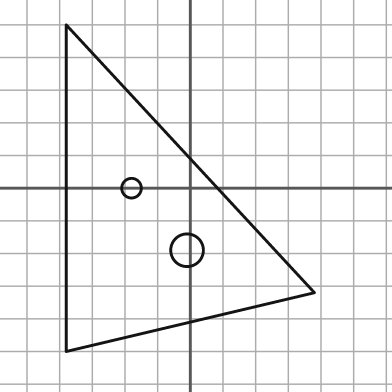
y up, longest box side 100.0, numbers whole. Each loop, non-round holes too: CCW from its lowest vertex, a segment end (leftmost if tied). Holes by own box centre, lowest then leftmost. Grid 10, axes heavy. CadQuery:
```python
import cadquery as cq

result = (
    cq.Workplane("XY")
    .moveTo(-38.0, -50.0)
    .lineTo(38.0, -32.0)
    .lineTo(-38.0, 50.0)
    .close()
    .moveTo(-1.0, -19.0)
    .circle(5.0)
    .moveTo(-18.0, 0.0)
    .circle(3.0)
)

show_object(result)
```